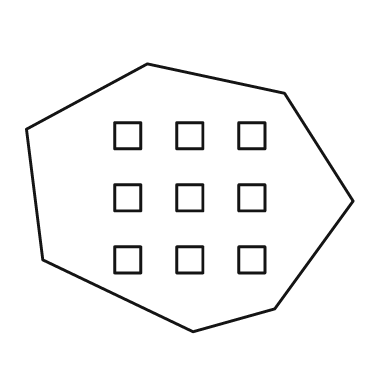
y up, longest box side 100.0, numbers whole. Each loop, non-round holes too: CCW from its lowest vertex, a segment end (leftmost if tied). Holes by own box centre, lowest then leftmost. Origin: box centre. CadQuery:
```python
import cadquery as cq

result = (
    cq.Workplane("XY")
    .moveTo(1.0, -41.0)
    .lineTo(26.0, -34.0)
    .lineTo(50.0, -1.0)
    .lineTo(29.0, 32.0)
    .lineTo(-13.0, 41.0)
    .lineTo(-50.0, 21.0)
    .lineTo(-45.0, -19.0)
    .close()
    .moveTo(-23.0, -23.0)
    .lineTo(-15.0, -23.0)
    .lineTo(-15.0, -15.0)
    .lineTo(-23.0, -15.0)
    .close()
    .moveTo(-4.0, -23.0)
    .lineTo(4.0, -23.0)
    .lineTo(4.0, -15.0)
    .lineTo(-4.0, -15.0)
    .close()
    .moveTo(15.0, -23.0)
    .lineTo(23.0, -23.0)
    .lineTo(23.0, -15.0)
    .lineTo(15.0, -15.0)
    .close()
    .moveTo(-23.0, -4.0)
    .lineTo(-15.0, -4.0)
    .lineTo(-15.0, 4.0)
    .lineTo(-23.0, 4.0)
    .close()
    .moveTo(-4.0, -4.0)
    .lineTo(4.0, -4.0)
    .lineTo(4.0, 4.0)
    .lineTo(-4.0, 4.0)
    .close()
    .moveTo(15.0, -4.0)
    .lineTo(23.0, -4.0)
    .lineTo(23.0, 4.0)
    .lineTo(15.0, 4.0)
    .close()
    .moveTo(-23.0, 15.0)
    .lineTo(-15.0, 15.0)
    .lineTo(-15.0, 23.0)
    .lineTo(-23.0, 23.0)
    .close()
    .moveTo(-4.0, 15.0)
    .lineTo(4.0, 15.0)
    .lineTo(4.0, 23.0)
    .lineTo(-4.0, 23.0)
    .close()
    .moveTo(15.0, 15.0)
    .lineTo(23.0, 15.0)
    .lineTo(23.0, 23.0)
    .lineTo(15.0, 23.0)
    .close()
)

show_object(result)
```